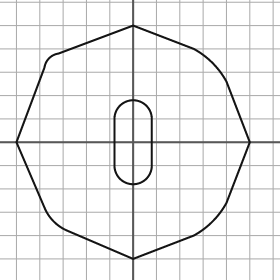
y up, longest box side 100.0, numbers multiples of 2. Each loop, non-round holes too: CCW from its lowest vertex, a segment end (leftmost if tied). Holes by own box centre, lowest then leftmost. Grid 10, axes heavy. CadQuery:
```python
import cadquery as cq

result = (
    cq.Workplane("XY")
    .moveTo(0.0, -50.0)
    .lineTo(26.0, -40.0)
    .threePointArc((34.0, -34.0), (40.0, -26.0))
    .lineTo(50.0, 0.0)
    .lineTo(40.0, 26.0)
    .threePointArc((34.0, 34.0), (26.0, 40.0))
    .lineTo(0.0, 50.0)
    .lineTo(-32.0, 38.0)
    .threePointArc((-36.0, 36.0), (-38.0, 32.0))
    .lineTo(-50.0, 0.0)
    .lineTo(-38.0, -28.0)
    .threePointArc((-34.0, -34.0), (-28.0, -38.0))
    .close()
    .moveTo(-8.0, -10.0)
    .threePointArc((0.0, -18.0), (8.0, -10.0))
    .lineTo(8.0, 10.0)
    .threePointArc((0.0, 18.0), (-8.0, 10.0))
    .close()
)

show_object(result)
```